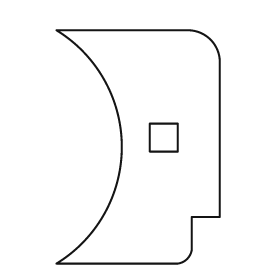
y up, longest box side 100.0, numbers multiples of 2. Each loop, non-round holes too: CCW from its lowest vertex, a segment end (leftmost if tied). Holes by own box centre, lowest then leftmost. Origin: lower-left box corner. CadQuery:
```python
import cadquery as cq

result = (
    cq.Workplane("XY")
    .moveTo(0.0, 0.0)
    .lineTo(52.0, 0.0)
    .threePointArc((56.0, 2.0), (58.0, 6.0))
    .lineTo(58.0, 20.0)
    .lineTo(70.0, 20.0)
    .lineTo(70.0, 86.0)
    .threePointArc((66.0, 96.0), (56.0, 100.0))
    .lineTo(0.0, 100.0)
    .threePointArc((28.0, 50.0), (0.0, 0.0))
    .close()
    .moveTo(40.0, 48.0)
    .lineTo(52.0, 48.0)
    .lineTo(52.0, 60.0)
    .lineTo(40.0, 60.0)
    .close()
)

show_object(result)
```